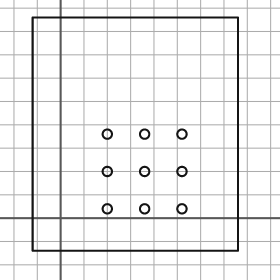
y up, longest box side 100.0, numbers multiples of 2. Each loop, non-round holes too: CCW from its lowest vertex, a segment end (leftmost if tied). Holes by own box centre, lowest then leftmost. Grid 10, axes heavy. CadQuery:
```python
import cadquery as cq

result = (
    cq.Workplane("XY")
    .moveTo(-12.0, -14.0)
    .lineTo(76.0, -14.0)
    .lineTo(76.0, 86.0)
    .lineTo(-12.0, 86.0)
    .close()
    .moveTo(20.0, 4.0)
    .circle(2.0)
    .moveTo(36.0, 4.0)
    .circle(2.0)
    .moveTo(52.0, 4.0)
    .circle(2.0)
    .moveTo(20.0, 20.0)
    .circle(2.0)
    .moveTo(36.0, 20.0)
    .circle(2.0)
    .moveTo(52.0, 20.0)
    .circle(2.0)
    .moveTo(20.0, 36.0)
    .circle(2.0)
    .moveTo(36.0, 36.0)
    .circle(2.0)
    .moveTo(52.0, 36.0)
    .circle(2.0)
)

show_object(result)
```